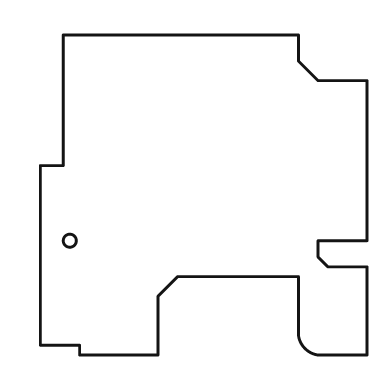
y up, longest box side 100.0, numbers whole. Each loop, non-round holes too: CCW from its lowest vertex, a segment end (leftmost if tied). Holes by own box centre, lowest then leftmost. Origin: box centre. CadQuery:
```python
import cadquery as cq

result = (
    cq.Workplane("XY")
    .moveTo(-38.0, -49.0)
    .lineTo(-14.0, -49.0)
    .lineTo(-14.0, -31.0)
    .lineTo(-8.0, -25.0)
    .lineTo(29.0, -25.0)
    .lineTo(29.0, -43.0)
    .threePointArc((31.0, -47.0), (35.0, -49.0))
    .lineTo(50.0, -49.0)
    .lineTo(50.0, -22.0)
    .lineTo(38.0, -22.0)
    .lineTo(35.0, -19.0)
    .lineTo(35.0, -14.0)
    .lineTo(50.0, -14.0)
    .lineTo(50.0, 35.0)
    .lineTo(35.0, 35.0)
    .lineTo(29.0, 41.0)
    .lineTo(29.0, 49.0)
    .lineTo(-43.0, 49.0)
    .lineTo(-43.0, 9.0)
    .lineTo(-50.0, 9.0)
    .lineTo(-50.0, -46.0)
    .lineTo(-38.0, -46.0)
    .close()
    .moveTo(-41.0, -14.0)
    .circle(2.0)
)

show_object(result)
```